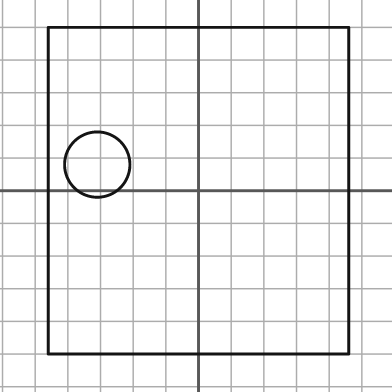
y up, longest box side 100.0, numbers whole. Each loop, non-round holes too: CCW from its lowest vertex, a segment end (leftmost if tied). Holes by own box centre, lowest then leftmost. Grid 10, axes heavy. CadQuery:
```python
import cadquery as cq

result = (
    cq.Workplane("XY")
    .moveTo(-46.0, -50.0)
    .lineTo(46.0, -50.0)
    .lineTo(46.0, 50.0)
    .lineTo(-46.0, 50.0)
    .close()
    .moveTo(-31.0, 8.0)
    .circle(10.0)
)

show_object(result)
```